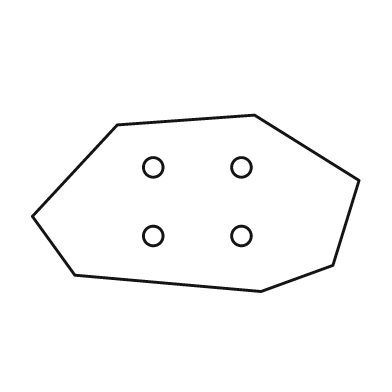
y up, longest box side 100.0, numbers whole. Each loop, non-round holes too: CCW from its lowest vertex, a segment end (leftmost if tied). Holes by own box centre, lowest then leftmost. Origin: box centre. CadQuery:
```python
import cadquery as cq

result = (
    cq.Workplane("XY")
    .moveTo(20.0, -27.0)
    .lineTo(42.0, -19.0)
    .lineTo(50.0, 7.0)
    .lineTo(18.0, 27.0)
    .lineTo(-24.0, 24.0)
    .lineTo(-50.0, -4.0)
    .lineTo(-37.0, -22.0)
    .close()
    .moveTo(-13.0, -10.0)
    .circle(3.0)
    .moveTo(14.0, -10.0)
    .circle(3.0)
    .moveTo(-13.0, 11.0)
    .circle(3.0)
    .moveTo(14.0, 11.0)
    .circle(3.0)
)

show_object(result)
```